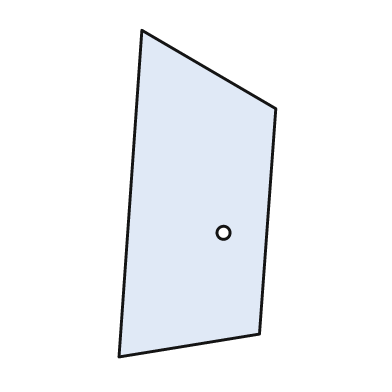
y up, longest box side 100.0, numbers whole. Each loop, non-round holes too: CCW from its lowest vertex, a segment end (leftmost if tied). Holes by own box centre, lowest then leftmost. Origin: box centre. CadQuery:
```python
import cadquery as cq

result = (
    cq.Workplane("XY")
    .moveTo(-24.0, -50.0)
    .lineTo(19.0, -43.0)
    .lineTo(24.0, 26.0)
    .lineTo(-17.0, 50.0)
    .close()
    .moveTo(8.0, -12.0)
    .circle(2.0)
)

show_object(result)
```